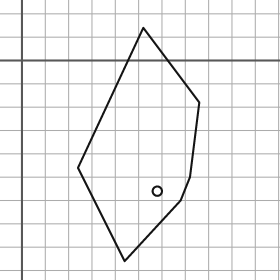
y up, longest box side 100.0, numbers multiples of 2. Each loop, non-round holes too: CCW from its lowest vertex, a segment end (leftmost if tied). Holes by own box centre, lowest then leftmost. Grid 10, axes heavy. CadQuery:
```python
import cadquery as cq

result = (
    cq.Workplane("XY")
    .moveTo(44.0, -86.0)
    .lineTo(68.0, -60.0)
    .lineTo(72.0, -50.0)
    .lineTo(76.0, -18.0)
    .lineTo(52.0, 14.0)
    .lineTo(24.0, -46.0)
    .close()
    .moveTo(58.0, -56.0)
    .circle(2.0)
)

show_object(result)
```